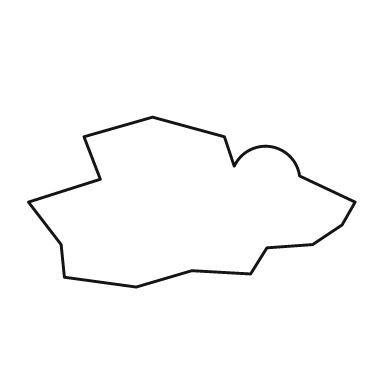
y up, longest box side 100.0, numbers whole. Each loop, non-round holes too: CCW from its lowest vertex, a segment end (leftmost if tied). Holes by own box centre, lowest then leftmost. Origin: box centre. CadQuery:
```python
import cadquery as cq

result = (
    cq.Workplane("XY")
    .moveTo(-17.0, -26.0)
    .lineTo(0.0, -21.0)
    .lineTo(18.0, -22.0)
    .lineTo(23.0, -14.0)
    .lineTo(37.0, -13.0)
    .lineTo(46.0, -7.0)
    .lineTo(50.0, 0.0)
    .lineTo(33.0, 8.0)
    .threePointArc((24.0, 17.0), (13.0, 11.0))
    .lineTo(10.0, 20.0)
    .lineTo(-12.0, 26.0)
    .lineTo(-33.0, 20.0)
    .lineTo(-28.0, 7.0)
    .lineTo(-50.0, 0.0)
    .lineTo(-40.0, -13.0)
    .lineTo(-39.0, -23.0)
    .close()
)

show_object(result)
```